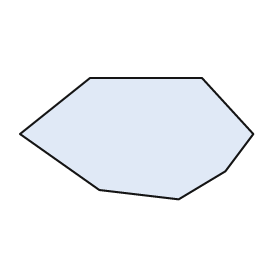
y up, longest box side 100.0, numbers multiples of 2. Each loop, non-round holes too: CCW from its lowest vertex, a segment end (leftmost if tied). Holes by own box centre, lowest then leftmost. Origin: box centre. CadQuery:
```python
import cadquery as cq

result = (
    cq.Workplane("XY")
    .moveTo(18.0, -26.0)
    .lineTo(38.0, -14.0)
    .lineTo(50.0, 2.0)
    .lineTo(28.0, 26.0)
    .lineTo(-20.0, 26.0)
    .lineTo(-50.0, 2.0)
    .lineTo(-16.0, -22.0)
    .close()
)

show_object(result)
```